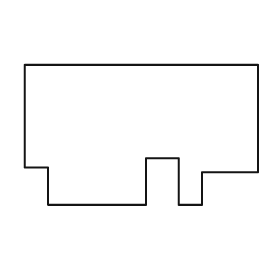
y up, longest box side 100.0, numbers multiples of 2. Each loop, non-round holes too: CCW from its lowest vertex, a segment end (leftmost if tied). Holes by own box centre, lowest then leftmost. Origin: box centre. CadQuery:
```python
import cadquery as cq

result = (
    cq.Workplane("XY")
    .moveTo(-40.0, -30.0)
    .lineTo(2.0, -30.0)
    .lineTo(2.0, -10.0)
    .lineTo(16.0, -10.0)
    .lineTo(16.0, -30.0)
    .lineTo(26.0, -30.0)
    .lineTo(26.0, -16.0)
    .lineTo(50.0, -16.0)
    .lineTo(50.0, 30.0)
    .lineTo(-50.0, 30.0)
    .lineTo(-50.0, -14.0)
    .lineTo(-40.0, -14.0)
    .close()
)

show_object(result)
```